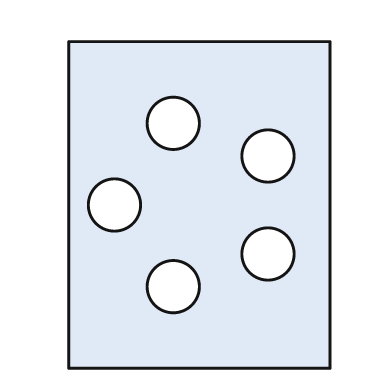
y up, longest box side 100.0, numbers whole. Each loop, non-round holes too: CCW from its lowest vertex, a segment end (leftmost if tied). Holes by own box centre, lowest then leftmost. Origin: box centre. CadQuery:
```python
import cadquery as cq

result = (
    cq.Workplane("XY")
    .moveTo(-40.0, -50.0)
    .lineTo(40.0, -50.0)
    .lineTo(40.0, 50.0)
    .lineTo(-40.0, 50.0)
    .close()
    .moveTo(-8.0, -25.0)
    .circle(8.0)
    .moveTo(21.0, -15.0)
    .circle(8.0)
    .moveTo(-26.0, 0.0)
    .circle(8.0)
    .moveTo(21.0, 15.0)
    .circle(8.0)
    .moveTo(-8.0, 25.0)
    .circle(8.0)
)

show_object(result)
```